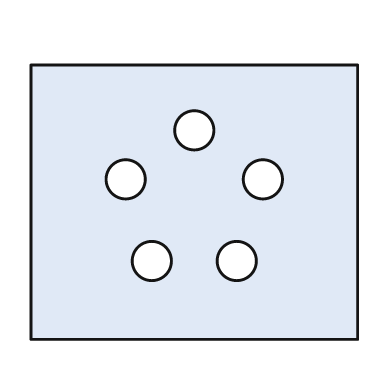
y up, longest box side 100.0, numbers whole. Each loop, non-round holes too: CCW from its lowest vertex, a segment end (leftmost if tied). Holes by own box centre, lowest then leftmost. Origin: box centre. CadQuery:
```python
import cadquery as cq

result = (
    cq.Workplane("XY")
    .moveTo(-50.0, -42.0)
    .lineTo(50.0, -42.0)
    .lineTo(50.0, 42.0)
    .lineTo(-50.0, 42.0)
    .close()
    .moveTo(-13.0, -18.0)
    .circle(6.0)
    .moveTo(13.0, -18.0)
    .circle(6.0)
    .moveTo(-21.0, 7.0)
    .circle(6.0)
    .moveTo(21.0, 7.0)
    .circle(6.0)
    .moveTo(0.0, 22.0)
    .circle(6.0)
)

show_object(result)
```